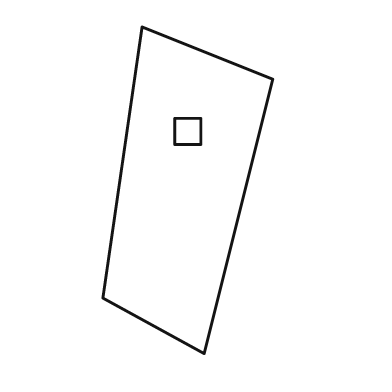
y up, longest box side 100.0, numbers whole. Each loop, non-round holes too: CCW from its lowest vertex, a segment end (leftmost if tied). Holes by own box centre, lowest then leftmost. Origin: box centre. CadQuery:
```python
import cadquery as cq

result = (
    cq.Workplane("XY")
    .moveTo(5.0, -50.0)
    .lineTo(26.0, 34.0)
    .lineTo(-14.0, 50.0)
    .lineTo(-26.0, -33.0)
    .close()
    .moveTo(-4.0, 14.0)
    .lineTo(4.0, 14.0)
    .lineTo(4.0, 22.0)
    .lineTo(-4.0, 22.0)
    .close()
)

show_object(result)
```